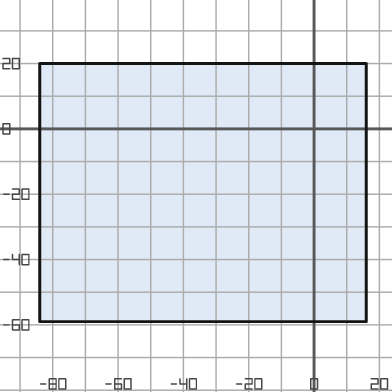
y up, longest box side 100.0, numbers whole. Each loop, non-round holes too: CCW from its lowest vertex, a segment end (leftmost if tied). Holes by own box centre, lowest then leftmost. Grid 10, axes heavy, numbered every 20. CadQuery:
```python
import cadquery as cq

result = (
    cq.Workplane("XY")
    .moveTo(-84.0, -59.0)
    .lineTo(16.0, -59.0)
    .lineTo(16.0, 20.0)
    .lineTo(-84.0, 20.0)
    .close()
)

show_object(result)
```